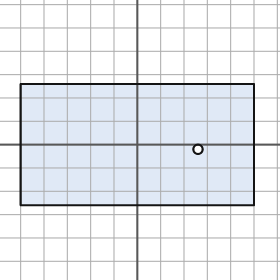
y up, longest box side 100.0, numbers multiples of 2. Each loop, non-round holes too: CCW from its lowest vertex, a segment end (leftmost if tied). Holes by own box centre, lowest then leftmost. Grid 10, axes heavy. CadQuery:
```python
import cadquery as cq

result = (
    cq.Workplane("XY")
    .moveTo(-50.0, -26.0)
    .lineTo(50.0, -26.0)
    .lineTo(50.0, 26.0)
    .lineTo(-50.0, 26.0)
    .close()
    .moveTo(26.0, -2.0)
    .circle(2.0)
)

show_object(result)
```